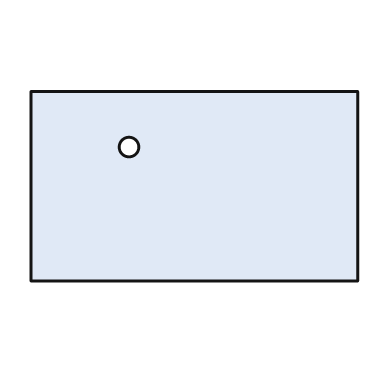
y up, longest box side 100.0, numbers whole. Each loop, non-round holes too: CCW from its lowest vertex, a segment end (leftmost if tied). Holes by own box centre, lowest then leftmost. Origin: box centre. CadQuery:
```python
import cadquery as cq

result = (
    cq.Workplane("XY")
    .moveTo(-50.0, -29.0)
    .lineTo(50.0, -29.0)
    .lineTo(50.0, 29.0)
    .lineTo(-50.0, 29.0)
    .close()
    .moveTo(-20.0, 12.0)
    .circle(3.0)
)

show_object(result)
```